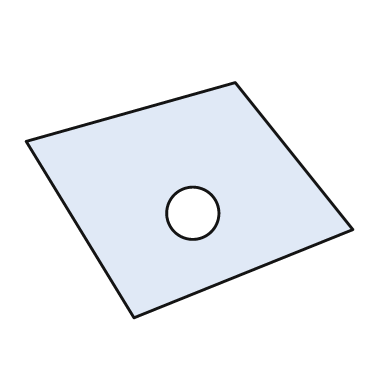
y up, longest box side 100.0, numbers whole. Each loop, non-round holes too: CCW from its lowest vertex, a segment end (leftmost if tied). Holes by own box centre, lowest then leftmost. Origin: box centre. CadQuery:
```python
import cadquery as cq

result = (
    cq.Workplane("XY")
    .moveTo(-17.0, -36.0)
    .lineTo(50.0, -9.0)
    .lineTo(14.0, 36.0)
    .lineTo(-50.0, 18.0)
    .close()
    .moveTo(1.0, -4.0)
    .circle(8.0)
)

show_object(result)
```